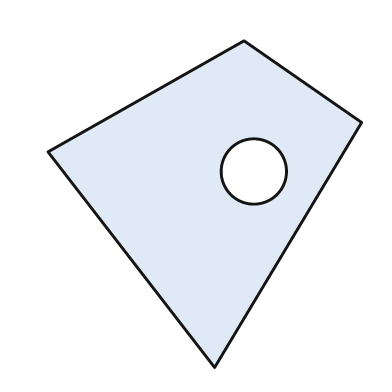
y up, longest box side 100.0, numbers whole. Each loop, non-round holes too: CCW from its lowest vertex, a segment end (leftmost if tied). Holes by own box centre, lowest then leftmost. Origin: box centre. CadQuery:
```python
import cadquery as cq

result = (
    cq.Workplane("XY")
    .moveTo(3.0, -50.0)
    .lineTo(48.0, 25.0)
    .lineTo(12.0, 50.0)
    .lineTo(-48.0, 16.0)
    .close()
    .moveTo(15.0, 10.0)
    .circle(10.0)
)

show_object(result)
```